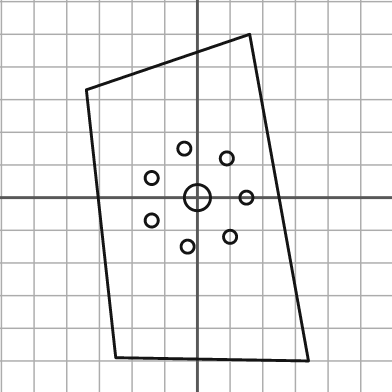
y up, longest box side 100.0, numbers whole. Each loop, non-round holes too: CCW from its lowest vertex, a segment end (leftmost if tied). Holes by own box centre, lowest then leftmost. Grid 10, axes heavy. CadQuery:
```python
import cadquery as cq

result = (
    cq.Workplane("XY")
    .moveTo(34.0, -50.0)
    .lineTo(16.0, 50.0)
    .lineTo(-34.0, 33.0)
    .lineTo(-25.0, -49.0)
    .close()
    .moveTo(-3.0, -15.0)
    .circle(2.0)
    .moveTo(10.0, -12.0)
    .circle(2.0)
    .moveTo(-14.0, -7.0)
    .circle(2.0)
    .moveTo(0.0, 0.0)
    .circle(4.0)
    .moveTo(15.0, 0.0)
    .circle(2.0)
    .moveTo(-14.0, 6.0)
    .circle(2.0)
    .moveTo(9.0, 12.0)
    .circle(2.0)
    .moveTo(-4.0, 15.0)
    .circle(2.0)
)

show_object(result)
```